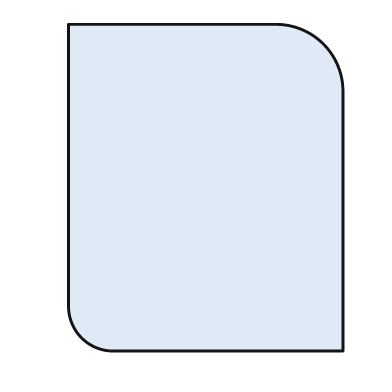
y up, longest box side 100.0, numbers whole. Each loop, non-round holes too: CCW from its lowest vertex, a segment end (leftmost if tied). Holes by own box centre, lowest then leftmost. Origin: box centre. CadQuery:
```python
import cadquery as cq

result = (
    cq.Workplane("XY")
    .moveTo(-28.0, -50.0)
    .lineTo(42.0, -50.0)
    .lineTo(42.0, 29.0)
    .threePointArc((36.0, 44.0), (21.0, 50.0))
    .lineTo(-42.0, 50.0)
    .lineTo(-42.0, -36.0)
    .threePointArc((-38.0, -46.0), (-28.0, -50.0))
    .close()
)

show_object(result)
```